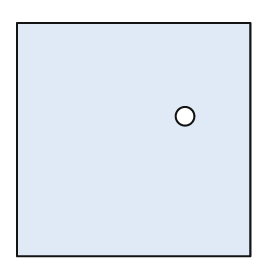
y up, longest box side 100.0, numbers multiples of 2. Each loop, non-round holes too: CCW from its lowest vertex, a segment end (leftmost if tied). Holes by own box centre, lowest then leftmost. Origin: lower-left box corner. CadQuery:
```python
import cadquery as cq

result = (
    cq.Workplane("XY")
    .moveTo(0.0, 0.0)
    .lineTo(100.0, 0.0)
    .lineTo(100.0, 100.0)
    .lineTo(0.0, 100.0)
    .close()
    .moveTo(72.0, 60.0)
    .circle(4.0)
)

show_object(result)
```